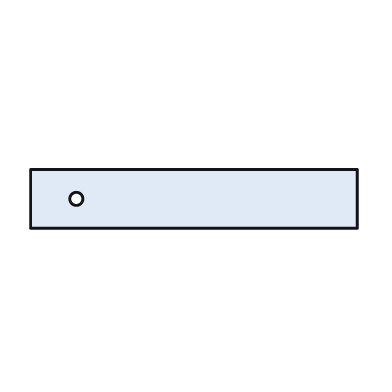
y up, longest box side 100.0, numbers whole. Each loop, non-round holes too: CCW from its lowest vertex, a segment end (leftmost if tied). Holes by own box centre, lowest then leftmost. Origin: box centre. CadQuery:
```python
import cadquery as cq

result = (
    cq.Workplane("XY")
    .moveTo(-50.0, -9.0)
    .lineTo(50.0, -9.0)
    .lineTo(50.0, 9.0)
    .lineTo(-50.0, 9.0)
    .close()
    .moveTo(-36.0, 0.0)
    .circle(2.0)
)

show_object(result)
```